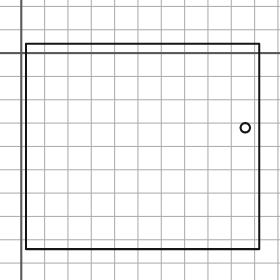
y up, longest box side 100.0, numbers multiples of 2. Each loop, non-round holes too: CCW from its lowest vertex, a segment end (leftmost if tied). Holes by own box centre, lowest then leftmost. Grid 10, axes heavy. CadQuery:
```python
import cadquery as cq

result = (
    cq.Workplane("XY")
    .moveTo(2.0, -84.0)
    .lineTo(102.0, -84.0)
    .lineTo(102.0, 4.0)
    .lineTo(2.0, 4.0)
    .close()
    .moveTo(96.0, -32.0)
    .circle(2.0)
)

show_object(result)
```